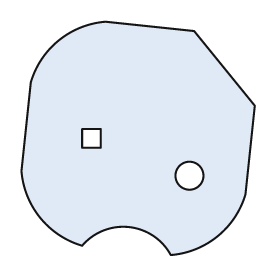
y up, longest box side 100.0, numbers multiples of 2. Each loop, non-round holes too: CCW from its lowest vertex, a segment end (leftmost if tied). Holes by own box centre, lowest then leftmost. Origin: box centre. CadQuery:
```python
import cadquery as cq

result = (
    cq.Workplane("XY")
    .moveTo(14.0, -50.0)
    .threePointArc((34.0, -42.0), (46.0, -24.0))
    .lineTo(50.0, 14.0)
    .lineTo(24.0, 46.0)
    .lineTo(-14.0, 50.0)
    .threePointArc((-34.0, 42.0), (-46.0, 24.0))
    .lineTo(-50.0, -14.0)
    .threePointArc((-42.0, -34.0), (-24.0, -46.0))
    .threePointArc((-4.0, -38.0), (14.0, -50.0))
    .close()
    .moveTo(22.0, -16.0)
    .circle(6.0)
    .moveTo(-24.0, -4.0)
    .lineTo(-16.0, -4.0)
    .lineTo(-16.0, 4.0)
    .lineTo(-24.0, 4.0)
    .close()
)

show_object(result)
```